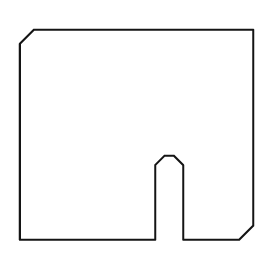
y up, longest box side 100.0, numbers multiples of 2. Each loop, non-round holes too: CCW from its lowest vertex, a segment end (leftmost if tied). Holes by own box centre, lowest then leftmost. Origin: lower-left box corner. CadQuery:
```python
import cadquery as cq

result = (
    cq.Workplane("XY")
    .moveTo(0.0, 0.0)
    .lineTo(58.0, 0.0)
    .lineTo(58.0, 32.0)
    .lineTo(62.0, 36.0)
    .lineTo(66.0, 36.0)
    .lineTo(70.0, 32.0)
    .lineTo(70.0, 0.0)
    .lineTo(94.0, 0.0)
    .lineTo(100.0, 6.0)
    .lineTo(100.0, 90.0)
    .lineTo(6.0, 90.0)
    .lineTo(0.0, 84.0)
    .close()
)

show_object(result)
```